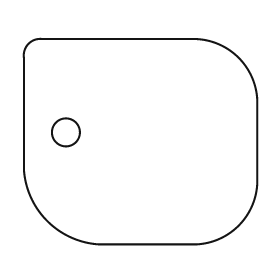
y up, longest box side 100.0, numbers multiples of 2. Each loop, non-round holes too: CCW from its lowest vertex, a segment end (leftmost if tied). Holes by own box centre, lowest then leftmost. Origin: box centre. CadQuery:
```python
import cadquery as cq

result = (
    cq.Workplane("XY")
    .moveTo(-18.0, -44.0)
    .lineTo(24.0, -44.0)
    .threePointArc((42.0, -36.0), (50.0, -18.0))
    .lineTo(50.0, 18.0)
    .threePointArc((42.0, 36.0), (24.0, 44.0))
    .lineTo(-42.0, 44.0)
    .threePointArc((-48.0, 42.0), (-50.0, 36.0))
    .lineTo(-50.0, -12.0)
    .threePointArc((-40.0, -34.0), (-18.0, -44.0))
    .close()
    .moveTo(-32.0, 4.0)
    .circle(6.0)
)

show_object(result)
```